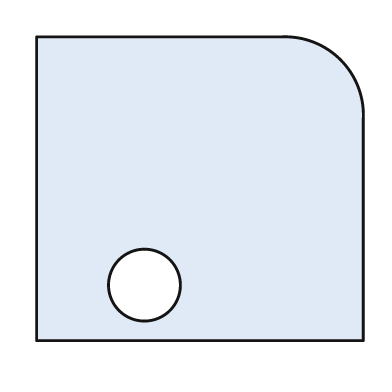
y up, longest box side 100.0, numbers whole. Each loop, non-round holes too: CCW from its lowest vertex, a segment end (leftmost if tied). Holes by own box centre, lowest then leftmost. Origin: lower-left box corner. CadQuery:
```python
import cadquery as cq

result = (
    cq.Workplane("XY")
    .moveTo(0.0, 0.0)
    .lineTo(100.0, 0.0)
    .lineTo(100.0, 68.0)
    .threePointArc((93.0, 86.0), (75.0, 93.0))
    .lineTo(0.0, 93.0)
    .close()
    .moveTo(33.0, 17.0)
    .circle(11.0)
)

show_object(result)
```